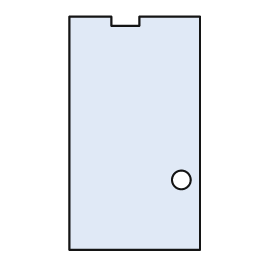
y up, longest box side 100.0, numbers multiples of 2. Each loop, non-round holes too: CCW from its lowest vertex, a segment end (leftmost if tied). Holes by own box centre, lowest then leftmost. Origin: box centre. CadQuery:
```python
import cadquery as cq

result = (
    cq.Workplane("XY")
    .moveTo(-28.0, -50.0)
    .lineTo(28.0, -50.0)
    .lineTo(28.0, 50.0)
    .lineTo(2.0, 50.0)
    .lineTo(2.0, 46.0)
    .lineTo(-10.0, 46.0)
    .lineTo(-10.0, 50.0)
    .lineTo(-28.0, 50.0)
    .close()
    .moveTo(20.0, -20.0)
    .circle(4.0)
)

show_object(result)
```